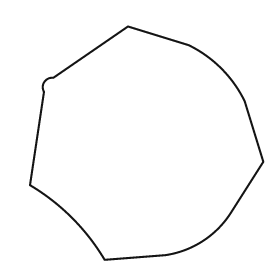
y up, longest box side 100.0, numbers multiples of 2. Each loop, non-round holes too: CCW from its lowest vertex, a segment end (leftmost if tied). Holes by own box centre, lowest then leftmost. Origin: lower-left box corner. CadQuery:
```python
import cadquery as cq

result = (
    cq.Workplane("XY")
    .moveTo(32.0, 0.0)
    .lineTo(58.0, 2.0)
    .threePointArc((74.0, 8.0), (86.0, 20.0))
    .lineTo(100.0, 42.0)
    .lineTo(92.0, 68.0)
    .threePointArc((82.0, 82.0), (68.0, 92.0))
    .lineTo(42.0, 100.0)
    .lineTo(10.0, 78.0)
    .threePointArc((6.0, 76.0), (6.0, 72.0))
    .lineTo(0.0, 32.0)
    .threePointArc((18.0, 18.0), (32.0, 0.0))
    .close()
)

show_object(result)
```